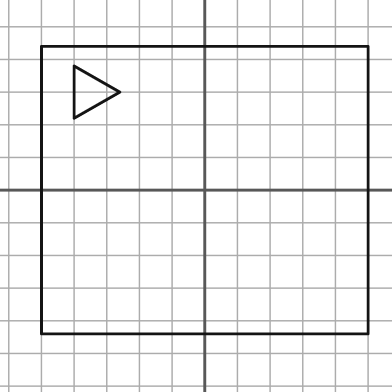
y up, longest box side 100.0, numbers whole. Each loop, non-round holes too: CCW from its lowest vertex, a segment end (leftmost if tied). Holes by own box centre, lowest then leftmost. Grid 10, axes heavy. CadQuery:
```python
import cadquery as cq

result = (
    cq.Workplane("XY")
    .moveTo(-50.0, -44.0)
    .lineTo(50.0, -44.0)
    .lineTo(50.0, 44.0)
    .lineTo(-50.0, 44.0)
    .close()
    .moveTo(-40.0, 22.0)
    .lineTo(-26.0, 30.0)
    .lineTo(-40.0, 38.0)
    .close()
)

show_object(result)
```